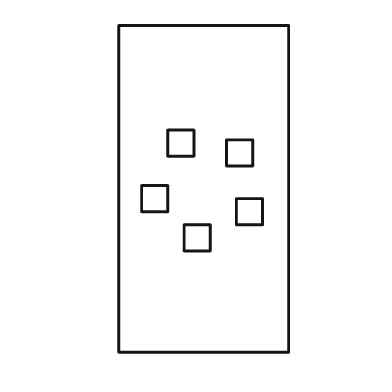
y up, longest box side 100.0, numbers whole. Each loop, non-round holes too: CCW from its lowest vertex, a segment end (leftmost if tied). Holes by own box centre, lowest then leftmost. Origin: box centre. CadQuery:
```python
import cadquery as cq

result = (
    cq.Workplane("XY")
    .moveTo(-26.0, -50.0)
    .lineTo(26.0, -50.0)
    .lineTo(26.0, 50.0)
    .lineTo(-26.0, 50.0)
    .close()
    .moveTo(-6.0, -19.0)
    .lineTo(2.0, -19.0)
    .lineTo(2.0, -11.0)
    .lineTo(-6.0, -11.0)
    .close()
    .moveTo(10.0, -11.0)
    .lineTo(18.0, -11.0)
    .lineTo(18.0, -3.0)
    .lineTo(10.0, -3.0)
    .close()
    .moveTo(-19.0, -7.0)
    .lineTo(-11.0, -7.0)
    .lineTo(-11.0, 1.0)
    .lineTo(-19.0, 1.0)
    .close()
    .moveTo(7.0, 7.0)
    .lineTo(15.0, 7.0)
    .lineTo(15.0, 15.0)
    .lineTo(7.0, 15.0)
    .close()
    .moveTo(-11.0, 10.0)
    .lineTo(-3.0, 10.0)
    .lineTo(-3.0, 18.0)
    .lineTo(-11.0, 18.0)
    .close()
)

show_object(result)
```